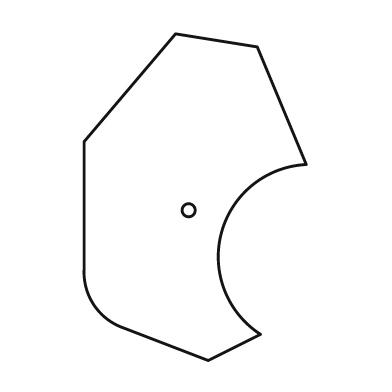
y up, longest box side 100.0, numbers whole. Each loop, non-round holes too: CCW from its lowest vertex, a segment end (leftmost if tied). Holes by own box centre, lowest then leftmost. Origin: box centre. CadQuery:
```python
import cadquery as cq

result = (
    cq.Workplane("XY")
    .moveTo(4.0, -50.0)
    .lineTo(20.0, -42.0)
    .threePointArc((8.0, -11.0), (34.0, 10.0))
    .lineTo(19.0, 46.0)
    .lineTo(-6.0, 50.0)
    .lineTo(-34.0, 17.0)
    .lineTo(-34.0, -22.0)
    .threePointArc((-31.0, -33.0), (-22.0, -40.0))
    .close()
    .moveTo(-2.0, -4.0)
    .circle(2.0)
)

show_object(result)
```